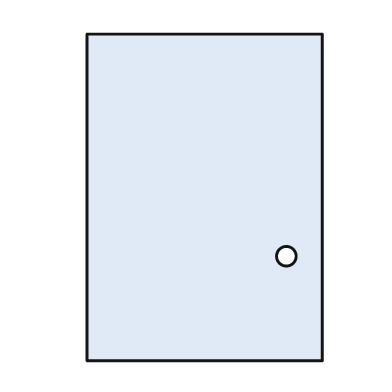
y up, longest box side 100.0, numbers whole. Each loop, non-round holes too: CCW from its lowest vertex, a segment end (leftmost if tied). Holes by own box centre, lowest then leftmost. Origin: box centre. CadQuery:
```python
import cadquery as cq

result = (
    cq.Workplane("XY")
    .moveTo(-36.0, -50.0)
    .lineTo(36.0, -50.0)
    .lineTo(36.0, 50.0)
    .lineTo(-36.0, 50.0)
    .close()
    .moveTo(25.0, -18.0)
    .circle(3.0)
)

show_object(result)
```